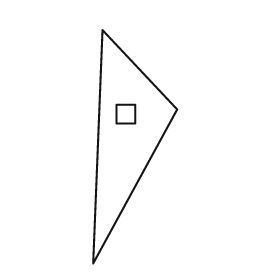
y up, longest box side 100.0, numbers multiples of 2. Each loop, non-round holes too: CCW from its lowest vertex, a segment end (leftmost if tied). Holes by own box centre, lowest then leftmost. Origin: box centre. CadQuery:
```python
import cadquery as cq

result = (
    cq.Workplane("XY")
    .moveTo(-18.0, -50.0)
    .lineTo(18.0, 16.0)
    .lineTo(-14.0, 50.0)
    .close()
    .moveTo(-8.0, 10.0)
    .lineTo(0.0, 10.0)
    .lineTo(0.0, 18.0)
    .lineTo(-8.0, 18.0)
    .close()
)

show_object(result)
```